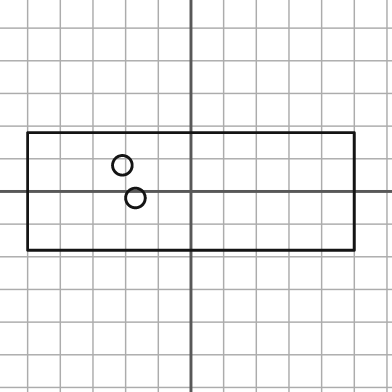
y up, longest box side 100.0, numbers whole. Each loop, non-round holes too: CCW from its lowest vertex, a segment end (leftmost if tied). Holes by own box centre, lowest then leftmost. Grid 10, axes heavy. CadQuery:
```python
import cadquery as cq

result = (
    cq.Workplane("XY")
    .moveTo(-50.0, -18.0)
    .lineTo(50.0, -18.0)
    .lineTo(50.0, 18.0)
    .lineTo(-50.0, 18.0)
    .close()
    .moveTo(-17.0, -2.0)
    .circle(3.0)
    .moveTo(-21.0, 8.0)
    .circle(3.0)
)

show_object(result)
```